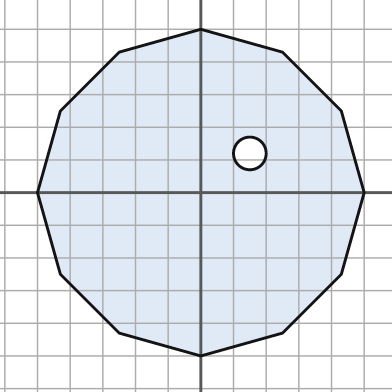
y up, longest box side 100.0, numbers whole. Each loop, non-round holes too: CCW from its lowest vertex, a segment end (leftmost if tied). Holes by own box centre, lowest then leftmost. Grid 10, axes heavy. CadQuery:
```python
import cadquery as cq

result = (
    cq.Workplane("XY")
    .moveTo(0.0, -50.0)
    .lineTo(25.0, -43.0)
    .lineTo(43.0, -25.0)
    .lineTo(50.0, 0.0)
    .lineTo(43.0, 25.0)
    .lineTo(25.0, 43.0)
    .lineTo(0.0, 50.0)
    .lineTo(-25.0, 43.0)
    .lineTo(-43.0, 25.0)
    .lineTo(-50.0, 0.0)
    .lineTo(-43.0, -25.0)
    .lineTo(-25.0, -43.0)
    .close()
    .moveTo(15.0, 12.0)
    .circle(5.0)
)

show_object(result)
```